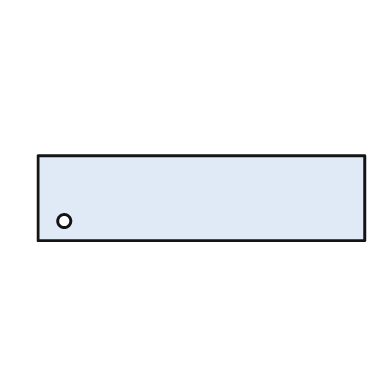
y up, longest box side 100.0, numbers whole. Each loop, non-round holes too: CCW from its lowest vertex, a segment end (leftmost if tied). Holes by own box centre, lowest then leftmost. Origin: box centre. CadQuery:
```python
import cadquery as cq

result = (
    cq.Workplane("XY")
    .moveTo(-50.0, -13.0)
    .lineTo(50.0, -13.0)
    .lineTo(50.0, 13.0)
    .lineTo(-50.0, 13.0)
    .close()
    .moveTo(-42.0, -7.0)
    .circle(2.0)
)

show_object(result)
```